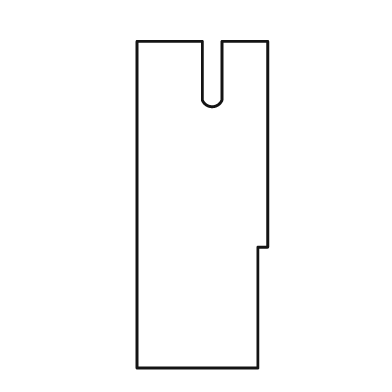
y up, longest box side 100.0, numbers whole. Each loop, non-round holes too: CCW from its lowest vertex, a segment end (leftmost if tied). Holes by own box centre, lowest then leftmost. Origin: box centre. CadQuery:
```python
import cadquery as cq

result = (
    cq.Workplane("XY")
    .moveTo(-20.0, -50.0)
    .lineTo(17.0, -50.0)
    .lineTo(17.0, -13.0)
    .lineTo(20.0, -13.0)
    .lineTo(20.0, 50.0)
    .lineTo(6.0, 50.0)
    .lineTo(6.0, 32.0)
    .threePointArc((3.0, 30.0), (0.0, 32.0))
    .lineTo(0.0, 50.0)
    .lineTo(-20.0, 50.0)
    .close()
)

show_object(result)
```